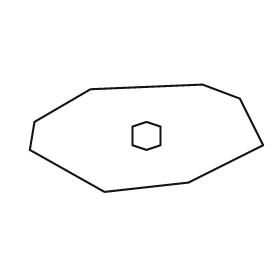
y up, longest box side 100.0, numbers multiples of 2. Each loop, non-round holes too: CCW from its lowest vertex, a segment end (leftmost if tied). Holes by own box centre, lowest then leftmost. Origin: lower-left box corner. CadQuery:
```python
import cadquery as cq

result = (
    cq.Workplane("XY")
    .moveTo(32.0, 0.0)
    .lineTo(68.0, 4.0)
    .lineTo(100.0, 20.0)
    .lineTo(90.0, 40.0)
    .lineTo(74.0, 46.0)
    .lineTo(26.0, 44.0)
    .lineTo(2.0, 30.0)
    .lineTo(0.0, 18.0)
    .close()
    .moveTo(50.0, 18.0)
    .lineTo(56.0, 20.0)
    .lineTo(56.0, 28.0)
    .lineTo(50.0, 30.0)
    .lineTo(44.0, 28.0)
    .lineTo(44.0, 20.0)
    .close()
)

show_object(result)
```